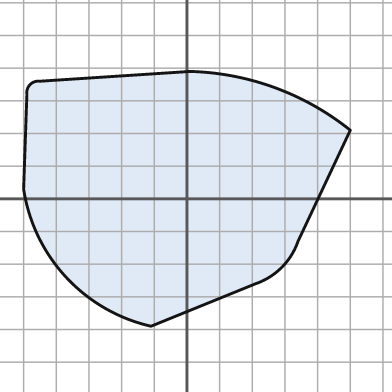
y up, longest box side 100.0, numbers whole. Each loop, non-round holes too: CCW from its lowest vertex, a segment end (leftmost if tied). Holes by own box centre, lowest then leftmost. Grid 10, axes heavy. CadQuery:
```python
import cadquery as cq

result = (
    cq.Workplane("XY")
    .moveTo(-11.0, -39.0)
    .lineTo(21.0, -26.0)
    .threePointArc((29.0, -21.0), (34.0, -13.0))
    .lineTo(50.0, 21.0)
    .threePointArc((27.0, 34.0), (1.0, 39.0))
    .lineTo(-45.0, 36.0)
    .threePointArc((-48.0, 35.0), (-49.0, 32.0))
    .lineTo(-50.0, 3.0)
    .threePointArc((-37.0, -24.0), (-11.0, -39.0))
    .close()
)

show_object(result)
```